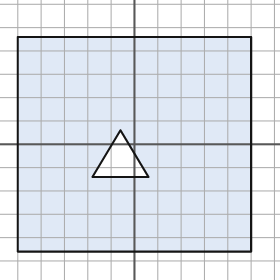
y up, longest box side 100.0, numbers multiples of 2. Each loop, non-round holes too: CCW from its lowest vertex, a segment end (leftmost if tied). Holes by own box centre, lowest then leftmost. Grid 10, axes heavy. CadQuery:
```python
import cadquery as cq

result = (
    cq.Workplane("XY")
    .moveTo(-50.0, -46.0)
    .lineTo(50.0, -46.0)
    .lineTo(50.0, 46.0)
    .lineTo(-50.0, 46.0)
    .close()
    .moveTo(-18.0, -14.0)
    .lineTo(6.0, -14.0)
    .lineTo(-6.0, 6.0)
    .close()
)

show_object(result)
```